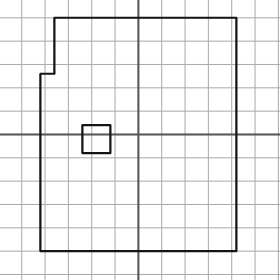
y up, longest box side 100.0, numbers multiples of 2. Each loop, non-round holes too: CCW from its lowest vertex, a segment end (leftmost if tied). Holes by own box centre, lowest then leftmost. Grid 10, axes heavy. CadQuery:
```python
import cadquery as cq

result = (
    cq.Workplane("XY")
    .moveTo(-42.0, -50.0)
    .lineTo(42.0, -50.0)
    .lineTo(42.0, 50.0)
    .lineTo(-36.0, 50.0)
    .lineTo(-36.0, 26.0)
    .lineTo(-42.0, 26.0)
    .close()
    .moveTo(-24.0, -8.0)
    .lineTo(-12.0, -8.0)
    .lineTo(-12.0, 4.0)
    .lineTo(-24.0, 4.0)
    .close()
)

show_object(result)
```